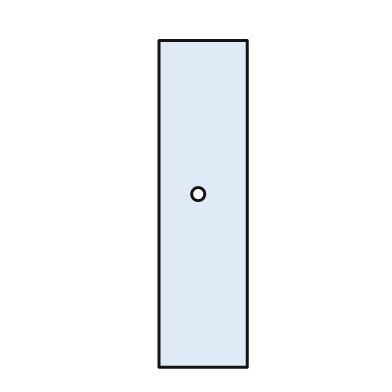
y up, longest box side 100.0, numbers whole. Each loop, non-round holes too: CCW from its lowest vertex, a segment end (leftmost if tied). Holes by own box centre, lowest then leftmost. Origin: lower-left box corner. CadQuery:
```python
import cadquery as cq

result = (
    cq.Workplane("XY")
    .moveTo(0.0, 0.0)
    .lineTo(27.0, 0.0)
    .lineTo(27.0, 100.0)
    .lineTo(0.0, 100.0)
    .close()
    .moveTo(12.0, 53.0)
    .circle(2.0)
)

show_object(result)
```